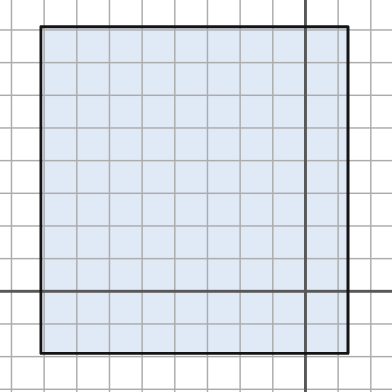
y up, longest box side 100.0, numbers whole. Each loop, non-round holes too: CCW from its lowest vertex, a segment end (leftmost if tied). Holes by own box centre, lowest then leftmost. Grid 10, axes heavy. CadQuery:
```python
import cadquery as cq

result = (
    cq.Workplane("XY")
    .moveTo(-81.0, -19.0)
    .lineTo(13.0, -19.0)
    .lineTo(13.0, 81.0)
    .lineTo(-81.0, 81.0)
    .close()
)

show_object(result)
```